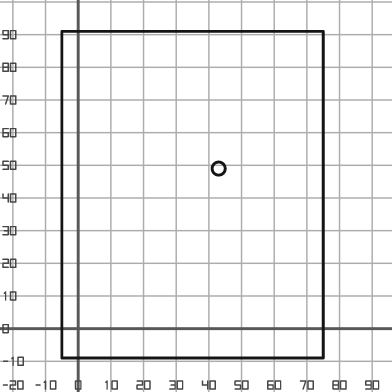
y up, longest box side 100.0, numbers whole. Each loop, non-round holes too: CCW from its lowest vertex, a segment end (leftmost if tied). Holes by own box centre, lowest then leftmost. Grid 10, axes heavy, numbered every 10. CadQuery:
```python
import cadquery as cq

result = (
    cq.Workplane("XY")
    .moveTo(-5.0, -9.0)
    .lineTo(75.0, -9.0)
    .lineTo(75.0, 91.0)
    .lineTo(-5.0, 91.0)
    .close()
    .moveTo(43.0, 49.0)
    .circle(2.0)
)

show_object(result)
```